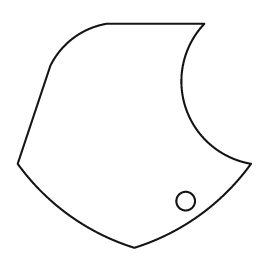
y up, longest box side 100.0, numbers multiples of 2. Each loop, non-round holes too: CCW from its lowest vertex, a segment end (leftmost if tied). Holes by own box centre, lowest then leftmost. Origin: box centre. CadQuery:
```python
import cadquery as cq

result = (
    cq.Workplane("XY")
    .moveTo(0.0, -48.0)
    .threePointArc((28.0, -34.0), (50.0, -12.0))
    .threePointArc((22.0, 12.0), (30.0, 48.0))
    .lineTo(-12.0, 48.0)
    .threePointArc((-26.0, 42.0), (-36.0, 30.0))
    .lineTo(-50.0, -12.0)
    .threePointArc((-28.0, -34.0), (0.0, -48.0))
    .close()
    .moveTo(22.0, -28.0)
    .circle(4.0)
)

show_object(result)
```